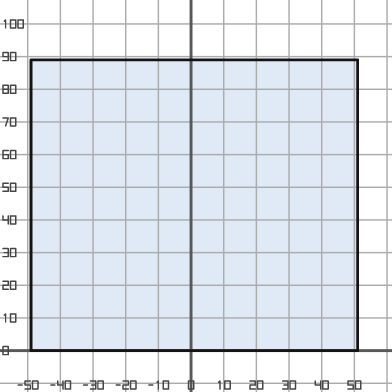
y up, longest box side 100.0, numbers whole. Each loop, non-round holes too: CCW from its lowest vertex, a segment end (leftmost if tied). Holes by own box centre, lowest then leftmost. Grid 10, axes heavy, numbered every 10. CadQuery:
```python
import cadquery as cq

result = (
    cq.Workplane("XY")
    .moveTo(-49.0, 0.0)
    .lineTo(51.0, 0.0)
    .lineTo(51.0, 89.0)
    .lineTo(-49.0, 89.0)
    .close()
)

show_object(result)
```